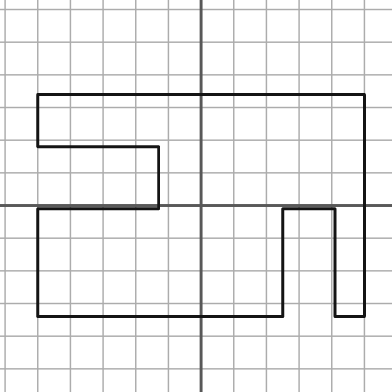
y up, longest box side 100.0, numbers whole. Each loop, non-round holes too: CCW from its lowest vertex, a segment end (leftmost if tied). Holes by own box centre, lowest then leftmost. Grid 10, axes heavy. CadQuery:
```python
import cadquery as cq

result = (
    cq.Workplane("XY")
    .moveTo(-50.0, -34.0)
    .lineTo(25.0, -34.0)
    .lineTo(25.0, -1.0)
    .lineTo(41.0, -1.0)
    .lineTo(41.0, -34.0)
    .lineTo(50.0, -34.0)
    .lineTo(50.0, 34.0)
    .lineTo(-50.0, 34.0)
    .lineTo(-50.0, 18.0)
    .lineTo(-13.0, 18.0)
    .lineTo(-13.0, -1.0)
    .lineTo(-50.0, -1.0)
    .close()
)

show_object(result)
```